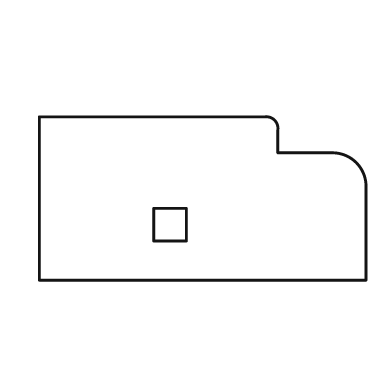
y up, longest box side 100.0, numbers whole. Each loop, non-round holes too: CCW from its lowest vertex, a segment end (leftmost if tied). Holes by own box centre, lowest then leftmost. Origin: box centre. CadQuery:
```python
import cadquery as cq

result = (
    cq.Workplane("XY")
    .moveTo(-50.0, -25.0)
    .lineTo(50.0, -25.0)
    .lineTo(50.0, 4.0)
    .threePointArc((47.0, 11.0), (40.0, 14.0))
    .lineTo(23.0, 14.0)
    .lineTo(23.0, 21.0)
    .threePointArc((22.0, 24.0), (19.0, 25.0))
    .lineTo(-50.0, 25.0)
    .close()
    .moveTo(-15.0, -13.0)
    .lineTo(-5.0, -13.0)
    .lineTo(-5.0, -3.0)
    .lineTo(-15.0, -3.0)
    .close()
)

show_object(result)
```